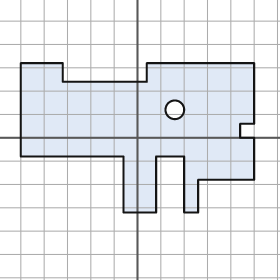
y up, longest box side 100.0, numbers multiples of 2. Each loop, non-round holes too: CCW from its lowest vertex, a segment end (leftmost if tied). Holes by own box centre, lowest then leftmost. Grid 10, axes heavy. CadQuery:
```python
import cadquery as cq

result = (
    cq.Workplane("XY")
    .moveTo(-6.0, -32.0)
    .lineTo(8.0, -32.0)
    .lineTo(8.0, -8.0)
    .lineTo(20.0, -8.0)
    .lineTo(20.0, -32.0)
    .lineTo(26.0, -32.0)
    .lineTo(26.0, -18.0)
    .lineTo(50.0, -18.0)
    .lineTo(50.0, 0.0)
    .lineTo(44.0, 0.0)
    .lineTo(44.0, 6.0)
    .lineTo(50.0, 6.0)
    .lineTo(50.0, 32.0)
    .lineTo(4.0, 32.0)
    .lineTo(4.0, 24.0)
    .lineTo(-32.0, 24.0)
    .lineTo(-32.0, 32.0)
    .lineTo(-50.0, 32.0)
    .lineTo(-50.0, -8.0)
    .lineTo(-6.0, -8.0)
    .close()
    .moveTo(16.0, 12.0)
    .circle(4.0)
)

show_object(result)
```